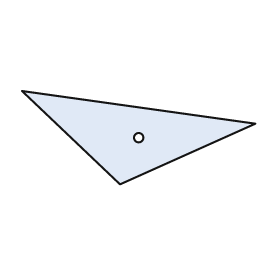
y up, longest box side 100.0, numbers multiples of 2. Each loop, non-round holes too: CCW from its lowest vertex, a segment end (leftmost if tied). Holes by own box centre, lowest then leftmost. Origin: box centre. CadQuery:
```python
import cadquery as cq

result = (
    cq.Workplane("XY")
    .moveTo(-8.0, -20.0)
    .lineTo(50.0, 6.0)
    .lineTo(-50.0, 20.0)
    .close()
    .moveTo(0.0, 0.0)
    .circle(2.0)
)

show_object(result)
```